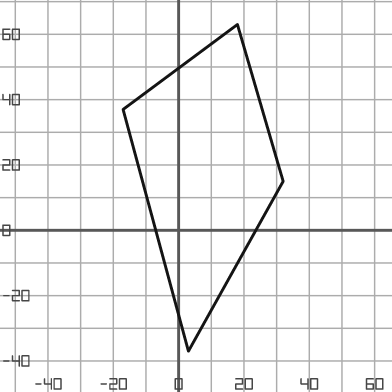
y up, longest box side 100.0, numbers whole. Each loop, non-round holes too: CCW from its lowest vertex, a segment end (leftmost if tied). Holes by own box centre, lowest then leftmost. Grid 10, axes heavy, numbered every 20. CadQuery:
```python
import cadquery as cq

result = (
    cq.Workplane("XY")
    .moveTo(3.0, -37.0)
    .lineTo(32.0, 15.0)
    .lineTo(18.0, 63.0)
    .lineTo(-17.0, 37.0)
    .close()
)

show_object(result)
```